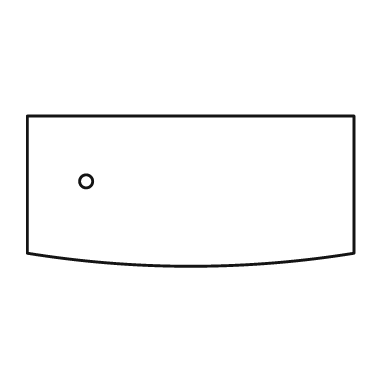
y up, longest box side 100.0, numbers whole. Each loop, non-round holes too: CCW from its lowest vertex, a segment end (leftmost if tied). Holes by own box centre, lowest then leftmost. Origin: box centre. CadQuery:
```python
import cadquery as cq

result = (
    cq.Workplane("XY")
    .moveTo(-50.0, -19.0)
    .threePointArc((0.0, -23.0), (50.0, -19.0))
    .lineTo(50.0, 23.0)
    .lineTo(-50.0, 23.0)
    .close()
    .moveTo(-32.0, 3.0)
    .circle(2.0)
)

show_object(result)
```